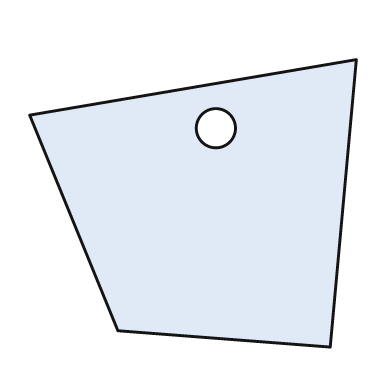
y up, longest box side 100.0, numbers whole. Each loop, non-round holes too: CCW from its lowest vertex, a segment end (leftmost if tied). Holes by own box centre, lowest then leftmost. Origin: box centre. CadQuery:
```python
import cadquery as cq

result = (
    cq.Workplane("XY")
    .moveTo(42.0, -44.0)
    .lineTo(50.0, 44.0)
    .lineTo(-50.0, 27.0)
    .lineTo(-23.0, -39.0)
    .close()
    .moveTo(7.0, 23.0)
    .circle(6.0)
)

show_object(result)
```